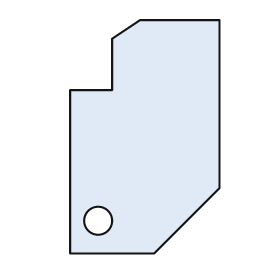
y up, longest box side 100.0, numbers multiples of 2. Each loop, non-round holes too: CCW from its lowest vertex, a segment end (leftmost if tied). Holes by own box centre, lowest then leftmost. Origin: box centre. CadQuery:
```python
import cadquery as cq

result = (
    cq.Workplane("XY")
    .moveTo(-32.0, -50.0)
    .lineTo(4.0, -50.0)
    .lineTo(32.0, -22.0)
    .lineTo(32.0, 50.0)
    .lineTo(-2.0, 50.0)
    .lineTo(-14.0, 42.0)
    .lineTo(-14.0, 20.0)
    .lineTo(-32.0, 20.0)
    .close()
    .moveTo(-20.0, -36.0)
    .circle(6.0)
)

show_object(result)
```